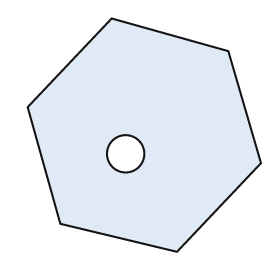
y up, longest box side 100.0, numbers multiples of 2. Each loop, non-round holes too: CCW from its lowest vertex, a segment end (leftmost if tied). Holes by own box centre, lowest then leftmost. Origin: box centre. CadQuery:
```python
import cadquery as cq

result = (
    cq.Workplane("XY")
    .moveTo(14.0, -50.0)
    .lineTo(50.0, -12.0)
    .lineTo(36.0, 36.0)
    .lineTo(-14.0, 50.0)
    .lineTo(-50.0, 12.0)
    .lineTo(-36.0, -38.0)
    .close()
    .moveTo(-8.0, -8.0)
    .circle(8.0)
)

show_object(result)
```